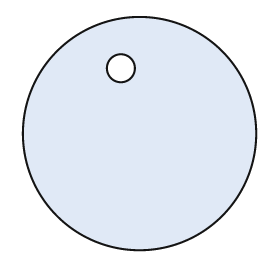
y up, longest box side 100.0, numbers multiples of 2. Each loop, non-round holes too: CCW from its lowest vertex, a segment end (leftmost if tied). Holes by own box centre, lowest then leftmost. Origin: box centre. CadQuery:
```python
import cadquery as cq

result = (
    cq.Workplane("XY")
    .moveTo(0.0, 0.0)
    .circle(50.0)
    .moveTo(-8.0, 28.0)
    .circle(6.0)
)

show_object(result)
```